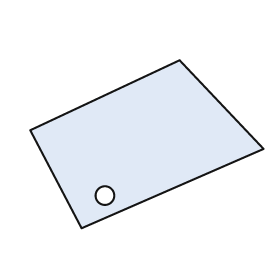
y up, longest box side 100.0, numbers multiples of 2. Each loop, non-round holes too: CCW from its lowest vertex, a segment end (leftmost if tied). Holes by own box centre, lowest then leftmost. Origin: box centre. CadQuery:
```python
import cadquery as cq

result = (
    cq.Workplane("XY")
    .moveTo(-28.0, -36.0)
    .lineTo(50.0, -2.0)
    .lineTo(14.0, 36.0)
    .lineTo(-50.0, 6.0)
    .close()
    .moveTo(-18.0, -22.0)
    .circle(4.0)
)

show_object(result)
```